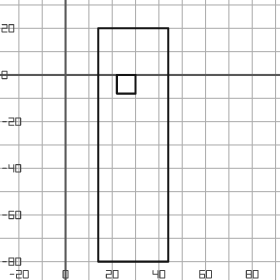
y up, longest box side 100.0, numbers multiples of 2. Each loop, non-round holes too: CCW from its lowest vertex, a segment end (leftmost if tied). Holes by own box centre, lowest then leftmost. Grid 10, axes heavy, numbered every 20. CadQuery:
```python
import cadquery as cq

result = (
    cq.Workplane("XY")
    .moveTo(14.0, -80.0)
    .lineTo(44.0, -80.0)
    .lineTo(44.0, 20.0)
    .lineTo(14.0, 20.0)
    .close()
    .moveTo(22.0, -8.0)
    .lineTo(30.0, -8.0)
    .lineTo(30.0, 0.0)
    .lineTo(22.0, 0.0)
    .close()
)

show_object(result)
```